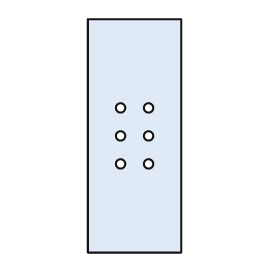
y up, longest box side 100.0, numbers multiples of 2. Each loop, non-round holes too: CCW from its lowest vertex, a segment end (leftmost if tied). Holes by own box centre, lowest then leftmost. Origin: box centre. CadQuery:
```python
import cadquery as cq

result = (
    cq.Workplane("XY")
    .moveTo(-20.0, -50.0)
    .lineTo(20.0, -50.0)
    .lineTo(20.0, 50.0)
    .lineTo(-20.0, 50.0)
    .close()
    .moveTo(-6.0, -12.0)
    .circle(2.0)
    .moveTo(6.0, -12.0)
    .circle(2.0)
    .moveTo(-6.0, 0.0)
    .circle(2.0)
    .moveTo(6.0, 0.0)
    .circle(2.0)
    .moveTo(-6.0, 12.0)
    .circle(2.0)
    .moveTo(6.0, 12.0)
    .circle(2.0)
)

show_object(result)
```